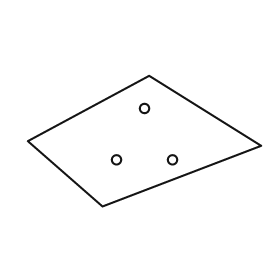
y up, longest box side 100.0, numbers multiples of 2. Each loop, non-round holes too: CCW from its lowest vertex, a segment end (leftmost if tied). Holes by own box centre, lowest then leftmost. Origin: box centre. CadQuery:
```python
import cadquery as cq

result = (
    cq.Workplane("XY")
    .moveTo(-18.0, -28.0)
    .lineTo(50.0, -2.0)
    .lineTo(2.0, 28.0)
    .lineTo(-50.0, 0.0)
    .close()
    .moveTo(-12.0, -8.0)
    .circle(2.0)
    .moveTo(12.0, -8.0)
    .circle(2.0)
    .moveTo(0.0, 14.0)
    .circle(2.0)
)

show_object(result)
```